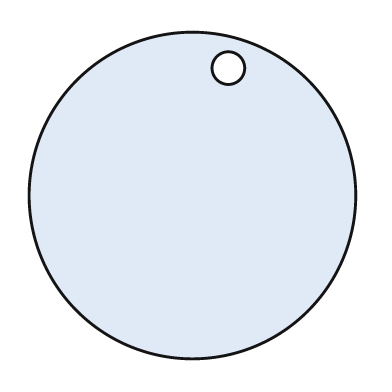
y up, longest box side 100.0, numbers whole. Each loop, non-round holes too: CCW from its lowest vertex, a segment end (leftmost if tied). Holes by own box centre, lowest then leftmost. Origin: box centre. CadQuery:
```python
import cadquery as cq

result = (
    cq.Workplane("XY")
    .moveTo(0.0, 0.0)
    .circle(50.0)
    .moveTo(11.0, 39.0)
    .circle(5.0)
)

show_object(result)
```